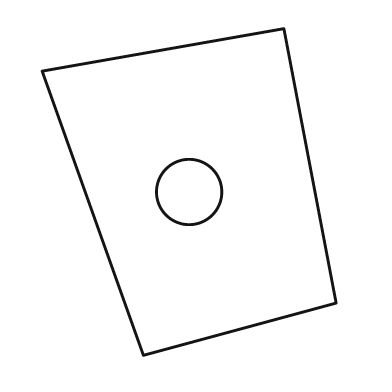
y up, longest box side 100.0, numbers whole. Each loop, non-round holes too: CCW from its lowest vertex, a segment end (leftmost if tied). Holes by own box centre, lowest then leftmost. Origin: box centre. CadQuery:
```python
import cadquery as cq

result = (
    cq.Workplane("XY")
    .moveTo(-14.0, -50.0)
    .lineTo(45.0, -34.0)
    .lineTo(29.0, 50.0)
    .lineTo(-45.0, 37.0)
    .close()
    .moveTo(0.0, 0.0)
    .circle(10.0)
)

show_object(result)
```